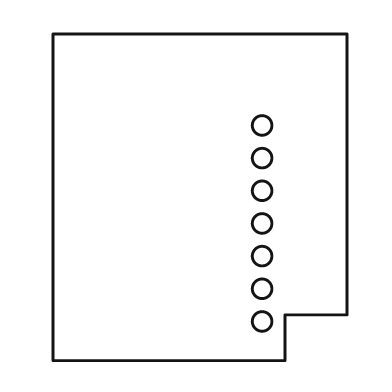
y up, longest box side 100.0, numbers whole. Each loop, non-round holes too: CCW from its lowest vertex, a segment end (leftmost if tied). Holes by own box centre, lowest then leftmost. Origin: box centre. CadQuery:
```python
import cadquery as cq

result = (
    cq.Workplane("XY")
    .moveTo(-45.0, -50.0)
    .lineTo(26.0, -50.0)
    .lineTo(26.0, -36.0)
    .lineTo(45.0, -36.0)
    .lineTo(45.0, 50.0)
    .lineTo(-45.0, 50.0)
    .close()
    .moveTo(19.0, -38.0)
    .circle(3.0)
    .moveTo(19.0, -28.0)
    .circle(3.0)
    .moveTo(19.0, -18.0)
    .circle(3.0)
    .moveTo(19.0, -8.0)
    .circle(3.0)
    .moveTo(19.0, 2.0)
    .circle(3.0)
    .moveTo(19.0, 12.0)
    .circle(3.0)
    .moveTo(19.0, 22.0)
    .circle(3.0)
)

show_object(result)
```